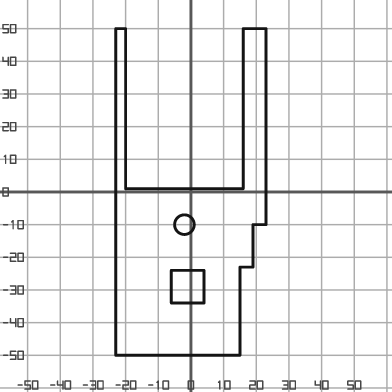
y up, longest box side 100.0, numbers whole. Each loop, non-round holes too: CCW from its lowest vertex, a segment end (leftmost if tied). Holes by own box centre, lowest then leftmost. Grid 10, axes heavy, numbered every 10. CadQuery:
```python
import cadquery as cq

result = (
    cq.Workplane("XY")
    .moveTo(-23.0, -50.0)
    .lineTo(15.0, -50.0)
    .lineTo(15.0, -23.0)
    .lineTo(19.0, -23.0)
    .lineTo(19.0, -10.0)
    .lineTo(23.0, -10.0)
    .lineTo(23.0, 50.0)
    .lineTo(16.0, 50.0)
    .lineTo(16.0, 1.0)
    .lineTo(-20.0, 1.0)
    .lineTo(-20.0, 50.0)
    .lineTo(-23.0, 50.0)
    .close()
    .moveTo(-6.0, -34.0)
    .lineTo(4.0, -34.0)
    .lineTo(4.0, -24.0)
    .lineTo(-6.0, -24.0)
    .close()
    .moveTo(-2.0, -10.0)
    .circle(3.0)
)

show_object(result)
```